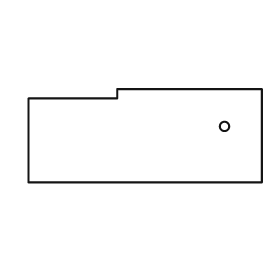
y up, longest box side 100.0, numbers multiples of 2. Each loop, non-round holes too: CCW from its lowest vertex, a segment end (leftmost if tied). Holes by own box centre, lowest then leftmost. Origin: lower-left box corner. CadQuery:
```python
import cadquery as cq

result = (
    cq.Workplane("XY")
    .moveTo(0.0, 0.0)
    .lineTo(100.0, 0.0)
    .lineTo(100.0, 40.0)
    .lineTo(38.0, 40.0)
    .lineTo(38.0, 36.0)
    .lineTo(0.0, 36.0)
    .close()
    .moveTo(84.0, 24.0)
    .circle(2.0)
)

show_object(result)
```